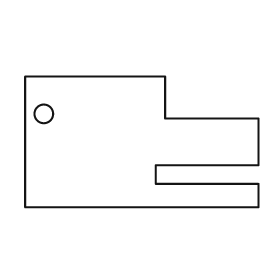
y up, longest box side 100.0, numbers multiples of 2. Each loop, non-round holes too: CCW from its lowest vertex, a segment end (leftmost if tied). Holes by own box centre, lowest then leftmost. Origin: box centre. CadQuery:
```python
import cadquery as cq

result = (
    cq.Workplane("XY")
    .moveTo(-50.0, -28.0)
    .lineTo(50.0, -28.0)
    .lineTo(50.0, -18.0)
    .lineTo(6.0, -18.0)
    .lineTo(6.0, -10.0)
    .lineTo(50.0, -10.0)
    .lineTo(50.0, 10.0)
    .lineTo(10.0, 10.0)
    .lineTo(10.0, 28.0)
    .lineTo(-50.0, 28.0)
    .close()
    .moveTo(-42.0, 12.0)
    .circle(4.0)
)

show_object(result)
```